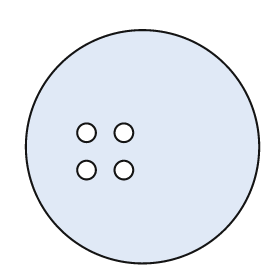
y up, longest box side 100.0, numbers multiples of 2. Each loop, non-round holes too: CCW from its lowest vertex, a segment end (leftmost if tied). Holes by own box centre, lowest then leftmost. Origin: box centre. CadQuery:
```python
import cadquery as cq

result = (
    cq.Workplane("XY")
    .moveTo(0.0, 0.0)
    .circle(50.0)
    .moveTo(-24.0, -10.0)
    .circle(4.0)
    .moveTo(-8.0, -10.0)
    .circle(4.0)
    .moveTo(-24.0, 6.0)
    .circle(4.0)
    .moveTo(-8.0, 6.0)
    .circle(4.0)
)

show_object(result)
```